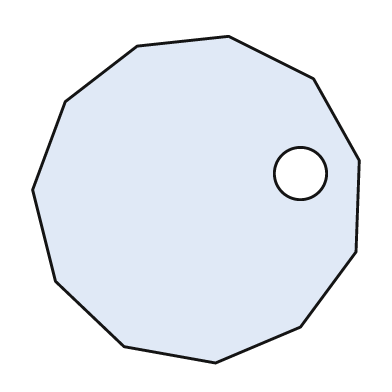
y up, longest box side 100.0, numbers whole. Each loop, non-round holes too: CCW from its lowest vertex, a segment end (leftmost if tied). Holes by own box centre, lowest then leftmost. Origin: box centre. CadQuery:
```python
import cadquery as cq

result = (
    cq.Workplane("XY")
    .moveTo(6.0, -50.0)
    .lineTo(32.0, -39.0)
    .lineTo(49.0, -16.0)
    .lineTo(50.0, 12.0)
    .lineTo(36.0, 37.0)
    .lineTo(10.0, 50.0)
    .lineTo(-18.0, 47.0)
    .lineTo(-40.0, 30.0)
    .lineTo(-50.0, 3.0)
    .lineTo(-43.0, -25.0)
    .lineTo(-22.0, -45.0)
    .close()
    .moveTo(32.0, 8.0)
    .circle(8.0)
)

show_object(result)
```